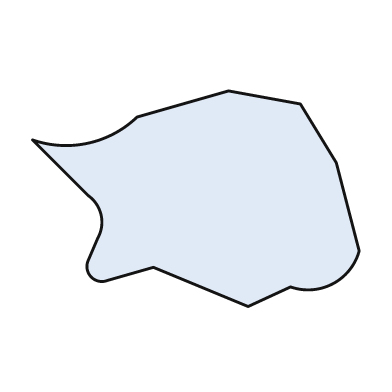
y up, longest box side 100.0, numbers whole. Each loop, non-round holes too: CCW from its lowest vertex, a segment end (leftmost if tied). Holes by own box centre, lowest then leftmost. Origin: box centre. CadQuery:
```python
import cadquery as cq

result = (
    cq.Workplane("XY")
    .moveTo(16.0, -33.0)
    .lineTo(29.0, -27.0)
    .threePointArc((42.0, -26.0), (50.0, -16.0))
    .lineTo(43.0, 11.0)
    .lineTo(32.0, 29.0)
    .lineTo(10.0, 33.0)
    .lineTo(-18.0, 25.0)
    .threePointArc((-33.0, 17.0), (-50.0, 18.0))
    .lineTo(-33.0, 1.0)
    .threePointArc((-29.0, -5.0), (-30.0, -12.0))
    .lineTo(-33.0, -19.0)
    .threePointArc((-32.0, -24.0), (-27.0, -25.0))
    .lineTo(-13.0, -21.0)
    .close()
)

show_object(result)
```